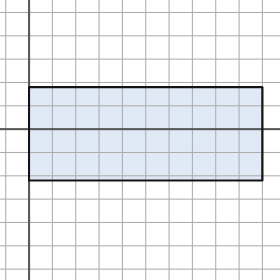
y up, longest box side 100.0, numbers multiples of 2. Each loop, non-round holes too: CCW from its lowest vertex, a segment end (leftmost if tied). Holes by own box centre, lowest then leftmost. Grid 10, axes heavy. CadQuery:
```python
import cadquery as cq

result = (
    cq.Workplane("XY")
    .moveTo(0.0, -22.0)
    .lineTo(100.0, -22.0)
    .lineTo(100.0, 18.0)
    .lineTo(0.0, 18.0)
    .close()
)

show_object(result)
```